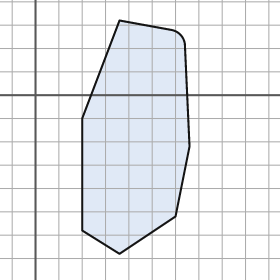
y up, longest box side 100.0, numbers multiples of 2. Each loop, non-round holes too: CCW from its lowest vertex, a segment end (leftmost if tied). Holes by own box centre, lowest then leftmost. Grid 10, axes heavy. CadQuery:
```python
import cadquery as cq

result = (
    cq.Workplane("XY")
    .moveTo(36.0, -68.0)
    .lineTo(60.0, -52.0)
    .lineTo(66.0, -22.0)
    .lineTo(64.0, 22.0)
    .threePointArc((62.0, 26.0), (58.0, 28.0))
    .lineTo(36.0, 32.0)
    .lineTo(20.0, -10.0)
    .lineTo(20.0, -58.0)
    .close()
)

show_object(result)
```